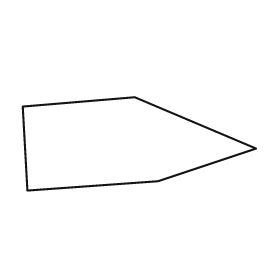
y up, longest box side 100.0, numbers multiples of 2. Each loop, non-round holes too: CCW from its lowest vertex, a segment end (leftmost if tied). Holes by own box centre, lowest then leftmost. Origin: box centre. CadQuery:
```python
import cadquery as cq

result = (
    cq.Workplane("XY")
    .moveTo(-48.0, -20.0)
    .lineTo(8.0, -16.0)
    .lineTo(50.0, -2.0)
    .lineTo(-2.0, 20.0)
    .lineTo(-50.0, 16.0)
    .close()
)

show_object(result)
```